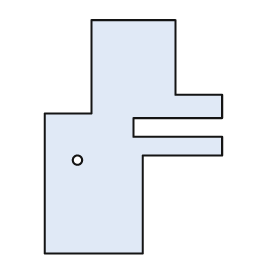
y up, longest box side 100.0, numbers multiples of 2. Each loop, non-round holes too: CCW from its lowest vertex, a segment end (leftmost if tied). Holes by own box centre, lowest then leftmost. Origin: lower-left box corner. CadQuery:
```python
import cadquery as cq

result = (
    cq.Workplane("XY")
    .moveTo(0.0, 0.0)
    .lineTo(42.0, 0.0)
    .lineTo(42.0, 42.0)
    .lineTo(76.0, 42.0)
    .lineTo(76.0, 50.0)
    .lineTo(38.0, 50.0)
    .lineTo(38.0, 58.0)
    .lineTo(76.0, 58.0)
    .lineTo(76.0, 68.0)
    .lineTo(56.0, 68.0)
    .lineTo(56.0, 100.0)
    .lineTo(20.0, 100.0)
    .lineTo(20.0, 60.0)
    .lineTo(0.0, 60.0)
    .close()
    .moveTo(14.0, 40.0)
    .circle(2.0)
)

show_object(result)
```